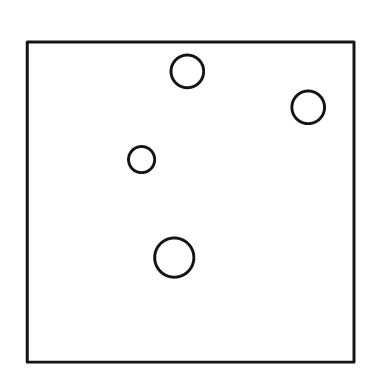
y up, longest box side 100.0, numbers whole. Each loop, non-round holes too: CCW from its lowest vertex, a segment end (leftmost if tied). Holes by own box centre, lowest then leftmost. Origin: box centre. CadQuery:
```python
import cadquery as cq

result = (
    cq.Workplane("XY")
    .moveTo(-50.0, -49.0)
    .lineTo(50.0, -49.0)
    .lineTo(50.0, 49.0)
    .lineTo(-50.0, 49.0)
    .close()
    .moveTo(-5.0, -17.0)
    .circle(6.0)
    .moveTo(-15.0, 13.0)
    .circle(4.0)
    .moveTo(36.0, 29.0)
    .circle(5.0)
    .moveTo(-1.0, 40.0)
    .circle(5.0)
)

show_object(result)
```